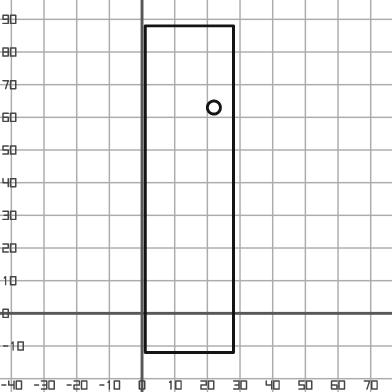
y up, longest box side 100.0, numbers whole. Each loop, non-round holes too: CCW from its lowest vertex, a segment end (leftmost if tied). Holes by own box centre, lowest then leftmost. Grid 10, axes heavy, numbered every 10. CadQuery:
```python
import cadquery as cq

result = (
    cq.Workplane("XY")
    .moveTo(1.0, -12.0)
    .lineTo(28.0, -12.0)
    .lineTo(28.0, 88.0)
    .lineTo(1.0, 88.0)
    .close()
    .moveTo(22.0, 63.0)
    .circle(2.0)
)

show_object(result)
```